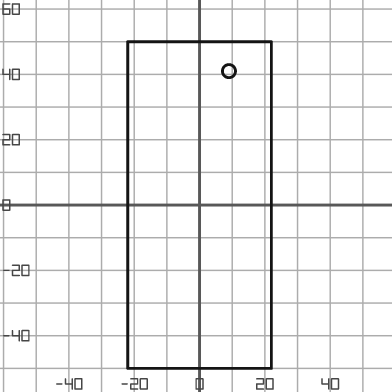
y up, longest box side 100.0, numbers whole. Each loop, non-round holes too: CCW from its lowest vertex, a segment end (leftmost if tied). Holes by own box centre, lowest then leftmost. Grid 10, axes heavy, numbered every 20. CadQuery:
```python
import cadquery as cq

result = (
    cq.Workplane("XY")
    .moveTo(-22.0, -50.0)
    .lineTo(22.0, -50.0)
    .lineTo(22.0, 50.0)
    .lineTo(-22.0, 50.0)
    .close()
    .moveTo(9.0, 41.0)
    .circle(2.0)
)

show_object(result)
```